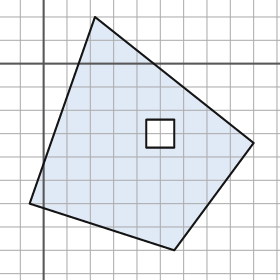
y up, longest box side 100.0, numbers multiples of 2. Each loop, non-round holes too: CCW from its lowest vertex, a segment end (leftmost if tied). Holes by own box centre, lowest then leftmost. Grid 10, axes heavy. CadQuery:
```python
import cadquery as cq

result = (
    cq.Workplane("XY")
    .moveTo(56.0, -80.0)
    .lineTo(90.0, -34.0)
    .lineTo(22.0, 20.0)
    .lineTo(-6.0, -60.0)
    .close()
    .moveTo(44.0, -36.0)
    .lineTo(56.0, -36.0)
    .lineTo(56.0, -24.0)
    .lineTo(44.0, -24.0)
    .close()
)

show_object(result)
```